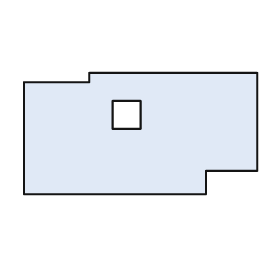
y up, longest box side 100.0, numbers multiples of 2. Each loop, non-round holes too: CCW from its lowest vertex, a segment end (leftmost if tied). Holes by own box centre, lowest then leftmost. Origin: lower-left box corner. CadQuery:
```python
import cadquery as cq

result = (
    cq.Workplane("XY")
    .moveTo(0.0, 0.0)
    .lineTo(78.0, 0.0)
    .lineTo(78.0, 10.0)
    .lineTo(100.0, 10.0)
    .lineTo(100.0, 52.0)
    .lineTo(28.0, 52.0)
    .lineTo(28.0, 48.0)
    .lineTo(0.0, 48.0)
    .close()
    .moveTo(38.0, 28.0)
    .lineTo(50.0, 28.0)
    .lineTo(50.0, 40.0)
    .lineTo(38.0, 40.0)
    .close()
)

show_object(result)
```